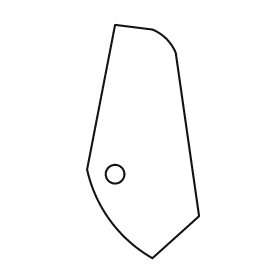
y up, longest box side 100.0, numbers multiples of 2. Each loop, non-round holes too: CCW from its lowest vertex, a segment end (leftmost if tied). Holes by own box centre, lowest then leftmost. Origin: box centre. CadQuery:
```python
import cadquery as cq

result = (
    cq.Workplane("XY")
    .moveTo(4.0, -50.0)
    .lineTo(24.0, -32.0)
    .lineTo(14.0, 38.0)
    .threePointArc((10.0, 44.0), (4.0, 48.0))
    .lineTo(-12.0, 50.0)
    .lineTo(-24.0, -12.0)
    .threePointArc((-14.0, -34.0), (4.0, -50.0))
    .close()
    .moveTo(-12.0, -14.0)
    .circle(4.0)
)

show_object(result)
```